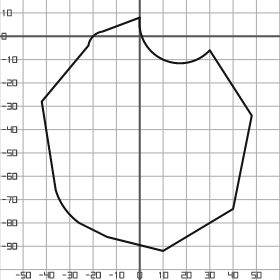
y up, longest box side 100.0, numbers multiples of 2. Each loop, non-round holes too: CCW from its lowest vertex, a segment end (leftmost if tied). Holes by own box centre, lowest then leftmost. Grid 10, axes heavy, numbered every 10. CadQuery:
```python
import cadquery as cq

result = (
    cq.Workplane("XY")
    .moveTo(10.0, -92.0)
    .lineTo(40.0, -74.0)
    .lineTo(48.0, -34.0)
    .lineTo(30.0, -6.0)
    .threePointArc((10.0, -10.0), (0.0, 8.0))
    .lineTo(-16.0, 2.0)
    .threePointArc((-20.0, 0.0), (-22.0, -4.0))
    .lineTo(-42.0, -28.0)
    .lineTo(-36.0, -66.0)
    .threePointArc((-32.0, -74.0), (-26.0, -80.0))
    .lineTo(-14.0, -86.0)
    .close()
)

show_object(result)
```